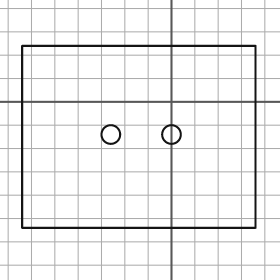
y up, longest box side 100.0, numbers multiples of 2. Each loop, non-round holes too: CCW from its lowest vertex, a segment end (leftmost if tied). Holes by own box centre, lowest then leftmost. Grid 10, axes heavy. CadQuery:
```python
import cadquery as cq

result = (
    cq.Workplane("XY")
    .moveTo(-64.0, -54.0)
    .lineTo(36.0, -54.0)
    .lineTo(36.0, 24.0)
    .lineTo(-64.0, 24.0)
    .close()
    .moveTo(-26.0, -14.0)
    .circle(4.0)
    .moveTo(0.0, -14.0)
    .circle(4.0)
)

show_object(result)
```